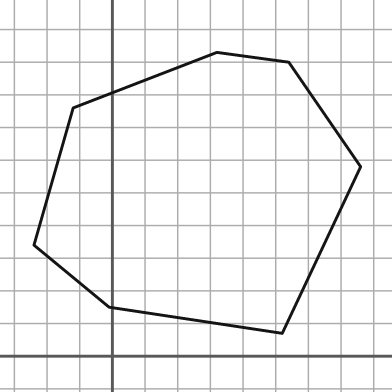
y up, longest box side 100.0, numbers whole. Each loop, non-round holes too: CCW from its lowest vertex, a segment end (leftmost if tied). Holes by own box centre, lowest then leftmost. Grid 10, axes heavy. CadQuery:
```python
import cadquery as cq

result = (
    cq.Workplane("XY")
    .moveTo(52.0, 7.0)
    .lineTo(76.0, 58.0)
    .lineTo(54.0, 90.0)
    .lineTo(32.0, 93.0)
    .lineTo(-12.0, 76.0)
    .lineTo(-24.0, 34.0)
    .lineTo(-1.0, 15.0)
    .close()
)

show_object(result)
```